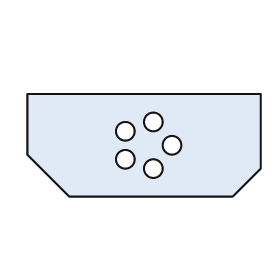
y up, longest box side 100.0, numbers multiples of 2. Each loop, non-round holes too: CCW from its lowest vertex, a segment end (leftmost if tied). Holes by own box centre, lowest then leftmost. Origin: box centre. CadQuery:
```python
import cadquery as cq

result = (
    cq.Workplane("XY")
    .moveTo(-32.0, -22.0)
    .lineTo(38.0, -22.0)
    .lineTo(50.0, -10.0)
    .lineTo(50.0, 22.0)
    .lineTo(-50.0, 22.0)
    .lineTo(-50.0, -4.0)
    .close()
    .moveTo(4.0, -10.0)
    .circle(4.0)
    .moveTo(-8.0, -6.0)
    .circle(4.0)
    .moveTo(12.0, 0.0)
    .circle(4.0)
    .moveTo(-8.0, 6.0)
    .circle(4.0)
    .moveTo(4.0, 10.0)
    .circle(4.0)
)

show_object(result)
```